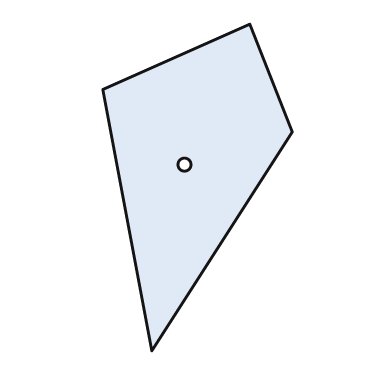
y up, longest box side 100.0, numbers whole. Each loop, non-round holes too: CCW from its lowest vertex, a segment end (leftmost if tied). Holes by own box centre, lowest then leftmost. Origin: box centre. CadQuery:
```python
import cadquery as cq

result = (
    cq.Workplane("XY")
    .moveTo(-14.0, -50.0)
    .lineTo(29.0, 17.0)
    .lineTo(16.0, 50.0)
    .lineTo(-29.0, 30.0)
    .close()
    .moveTo(-4.0, 7.0)
    .circle(2.0)
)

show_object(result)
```